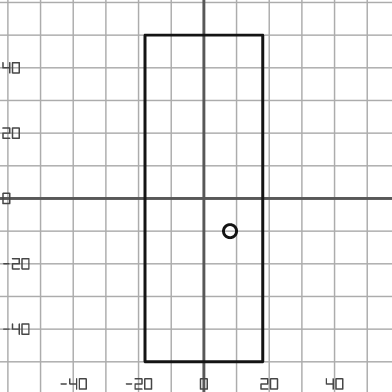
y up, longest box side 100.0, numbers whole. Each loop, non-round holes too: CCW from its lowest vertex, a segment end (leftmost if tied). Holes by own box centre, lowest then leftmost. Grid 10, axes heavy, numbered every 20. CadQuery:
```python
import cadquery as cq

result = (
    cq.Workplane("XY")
    .moveTo(-18.0, -50.0)
    .lineTo(18.0, -50.0)
    .lineTo(18.0, 50.0)
    .lineTo(-18.0, 50.0)
    .close()
    .moveTo(8.0, -10.0)
    .circle(2.0)
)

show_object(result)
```